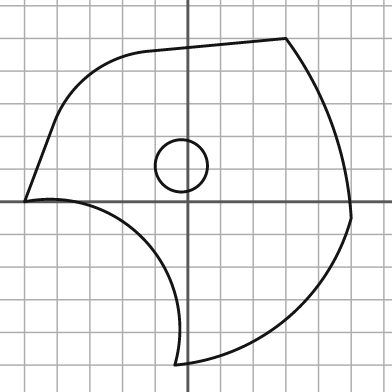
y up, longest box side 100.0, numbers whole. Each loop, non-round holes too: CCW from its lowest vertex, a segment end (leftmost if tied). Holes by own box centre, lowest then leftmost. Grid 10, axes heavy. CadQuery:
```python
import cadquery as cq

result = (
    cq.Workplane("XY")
    .moveTo(-4.0, -50.0)
    .threePointArc((30.0, -36.0), (50.0, -5.0))
    .threePointArc((44.0, 24.0), (30.0, 50.0))
    .lineTo(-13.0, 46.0)
    .threePointArc((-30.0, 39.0), (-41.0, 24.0))
    .lineTo(-50.0, 0.0)
    .threePointArc((-13.0, -12.0), (-4.0, -50.0))
    .close()
    .moveTo(-2.0, 11.0)
    .circle(8.0)
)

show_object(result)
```